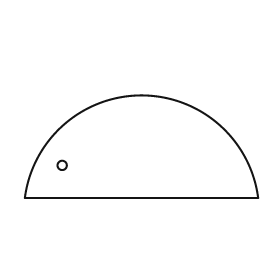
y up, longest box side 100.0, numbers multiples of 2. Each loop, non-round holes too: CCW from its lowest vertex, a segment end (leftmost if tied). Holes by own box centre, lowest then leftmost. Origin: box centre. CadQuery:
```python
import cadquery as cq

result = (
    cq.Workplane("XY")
    .moveTo(-50.0, -22.0)
    .lineTo(50.0, -22.0)
    .threePointArc((0.0, 22.0), (-50.0, -22.0))
    .close()
    .moveTo(-34.0, -8.0)
    .circle(2.0)
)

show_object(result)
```